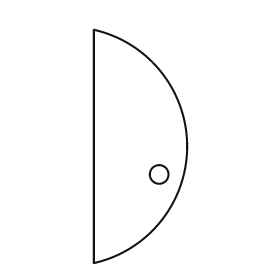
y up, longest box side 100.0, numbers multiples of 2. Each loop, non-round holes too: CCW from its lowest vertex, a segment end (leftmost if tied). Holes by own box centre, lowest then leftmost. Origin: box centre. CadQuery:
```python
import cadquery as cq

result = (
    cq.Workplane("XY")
    .moveTo(-20.0, -50.0)
    .threePointArc((20.0, 0.0), (-20.0, 50.0))
    .close()
    .moveTo(8.0, -12.0)
    .circle(4.0)
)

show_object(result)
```